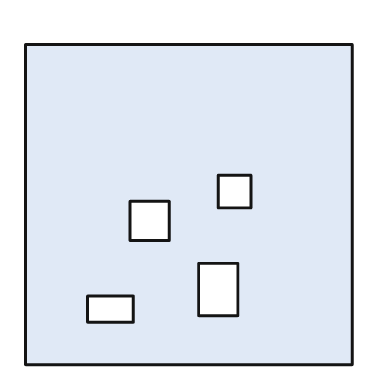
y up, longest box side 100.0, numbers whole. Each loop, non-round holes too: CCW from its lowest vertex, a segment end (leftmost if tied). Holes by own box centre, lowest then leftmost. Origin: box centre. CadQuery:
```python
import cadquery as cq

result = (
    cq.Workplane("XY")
    .moveTo(-50.0, -49.0)
    .lineTo(50.0, -49.0)
    .lineTo(50.0, 49.0)
    .lineTo(-50.0, 49.0)
    .close()
    .moveTo(-31.0, -36.0)
    .lineTo(-17.0, -36.0)
    .lineTo(-17.0, -28.0)
    .lineTo(-31.0, -28.0)
    .close()
    .moveTo(3.0, -34.0)
    .lineTo(15.0, -34.0)
    .lineTo(15.0, -18.0)
    .lineTo(3.0, -18.0)
    .close()
    .moveTo(-18.0, -11.0)
    .lineTo(-6.0, -11.0)
    .lineTo(-6.0, 1.0)
    .lineTo(-18.0, 1.0)
    .close()
    .moveTo(9.0, -1.0)
    .lineTo(19.0, -1.0)
    .lineTo(19.0, 9.0)
    .lineTo(9.0, 9.0)
    .close()
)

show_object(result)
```